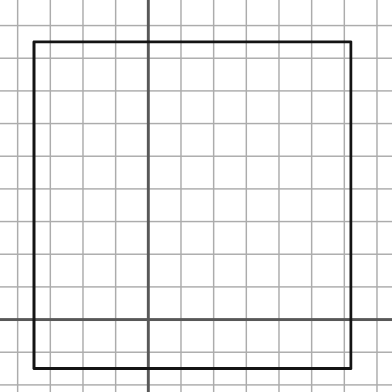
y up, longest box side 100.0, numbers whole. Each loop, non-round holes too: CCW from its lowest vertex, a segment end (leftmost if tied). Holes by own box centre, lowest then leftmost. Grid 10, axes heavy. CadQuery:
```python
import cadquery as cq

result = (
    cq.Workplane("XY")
    .moveTo(-35.0, -15.0)
    .lineTo(62.0, -15.0)
    .lineTo(62.0, 85.0)
    .lineTo(-35.0, 85.0)
    .close()
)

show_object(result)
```